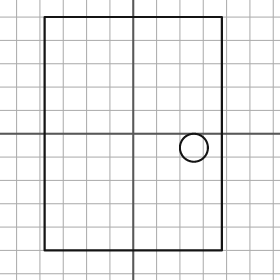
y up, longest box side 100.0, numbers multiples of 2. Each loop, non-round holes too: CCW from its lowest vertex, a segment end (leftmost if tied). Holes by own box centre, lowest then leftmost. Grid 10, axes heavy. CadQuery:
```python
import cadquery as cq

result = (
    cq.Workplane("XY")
    .moveTo(-38.0, -50.0)
    .lineTo(38.0, -50.0)
    .lineTo(38.0, 50.0)
    .lineTo(-38.0, 50.0)
    .close()
    .moveTo(26.0, -6.0)
    .circle(6.0)
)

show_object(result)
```